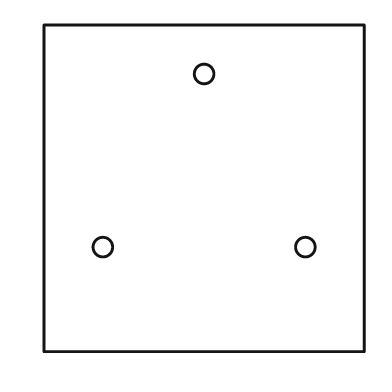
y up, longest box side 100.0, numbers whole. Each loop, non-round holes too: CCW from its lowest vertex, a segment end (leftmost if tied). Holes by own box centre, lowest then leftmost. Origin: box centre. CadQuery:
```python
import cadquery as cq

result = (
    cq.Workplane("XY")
    .moveTo(-49.0, -50.0)
    .lineTo(49.0, -50.0)
    .lineTo(49.0, 50.0)
    .lineTo(-49.0, 50.0)
    .close()
    .moveTo(-31.0, -18.0)
    .circle(3.0)
    .moveTo(31.0, -18.0)
    .circle(3.0)
    .moveTo(0.0, 35.0)
    .circle(3.0)
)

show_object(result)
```